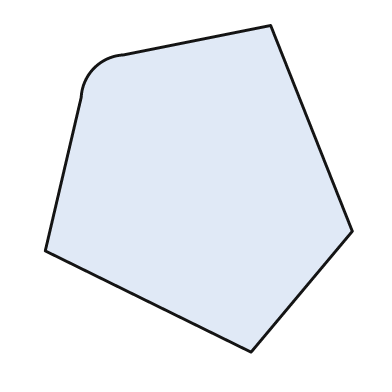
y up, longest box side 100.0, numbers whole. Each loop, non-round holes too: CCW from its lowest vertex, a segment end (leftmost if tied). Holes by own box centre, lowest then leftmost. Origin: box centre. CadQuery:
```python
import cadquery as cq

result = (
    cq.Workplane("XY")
    .moveTo(16.0, -50.0)
    .lineTo(47.0, -13.0)
    .lineTo(22.0, 50.0)
    .lineTo(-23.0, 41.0)
    .threePointArc((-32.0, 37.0), (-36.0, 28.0))
    .lineTo(-47.0, -19.0)
    .close()
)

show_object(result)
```